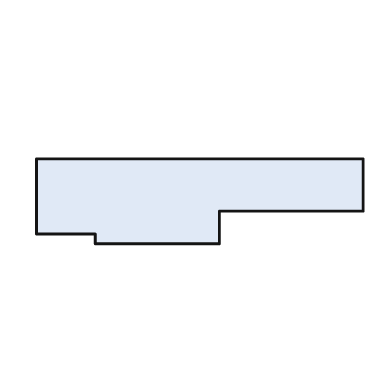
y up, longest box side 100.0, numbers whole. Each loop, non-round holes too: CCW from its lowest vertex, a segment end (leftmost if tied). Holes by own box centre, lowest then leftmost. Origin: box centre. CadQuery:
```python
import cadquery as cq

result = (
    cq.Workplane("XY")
    .moveTo(-32.0, -13.0)
    .lineTo(6.0, -13.0)
    .lineTo(6.0, -3.0)
    .lineTo(50.0, -3.0)
    .lineTo(50.0, 13.0)
    .lineTo(-50.0, 13.0)
    .lineTo(-50.0, -10.0)
    .lineTo(-32.0, -10.0)
    .close()
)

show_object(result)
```